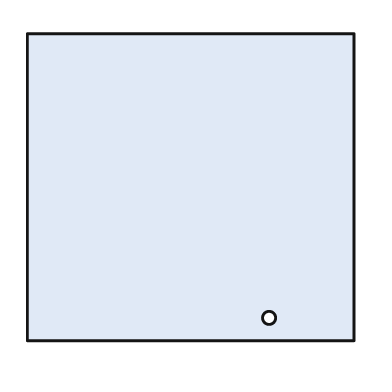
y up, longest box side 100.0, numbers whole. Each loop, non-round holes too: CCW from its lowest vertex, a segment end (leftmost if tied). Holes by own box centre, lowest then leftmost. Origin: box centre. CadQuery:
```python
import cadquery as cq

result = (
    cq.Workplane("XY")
    .moveTo(-50.0, -47.0)
    .lineTo(50.0, -47.0)
    .lineTo(50.0, 47.0)
    .lineTo(-50.0, 47.0)
    .close()
    .moveTo(24.0, -40.0)
    .circle(2.0)
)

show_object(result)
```